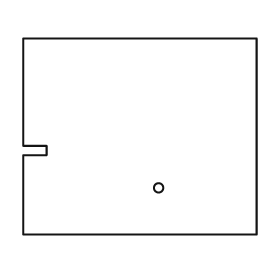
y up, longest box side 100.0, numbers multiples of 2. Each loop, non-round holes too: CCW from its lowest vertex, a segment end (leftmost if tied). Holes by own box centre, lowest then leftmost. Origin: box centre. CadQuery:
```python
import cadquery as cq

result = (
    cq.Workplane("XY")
    .moveTo(-50.0, -42.0)
    .lineTo(50.0, -42.0)
    .lineTo(50.0, 42.0)
    .lineTo(-50.0, 42.0)
    .lineTo(-50.0, -4.0)
    .lineTo(-40.0, -4.0)
    .lineTo(-40.0, -8.0)
    .lineTo(-50.0, -8.0)
    .close()
    .moveTo(8.0, -22.0)
    .circle(2.0)
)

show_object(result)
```